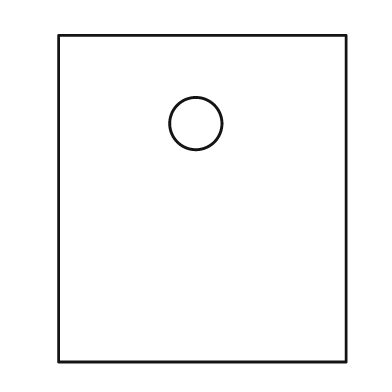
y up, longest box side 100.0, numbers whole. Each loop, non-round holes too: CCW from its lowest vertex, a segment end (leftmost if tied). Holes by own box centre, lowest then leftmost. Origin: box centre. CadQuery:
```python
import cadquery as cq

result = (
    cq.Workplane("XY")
    .moveTo(-44.0, -50.0)
    .lineTo(44.0, -50.0)
    .lineTo(44.0, 50.0)
    .lineTo(-44.0, 50.0)
    .close()
    .moveTo(-2.0, 23.0)
    .circle(8.0)
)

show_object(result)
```